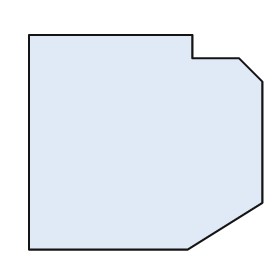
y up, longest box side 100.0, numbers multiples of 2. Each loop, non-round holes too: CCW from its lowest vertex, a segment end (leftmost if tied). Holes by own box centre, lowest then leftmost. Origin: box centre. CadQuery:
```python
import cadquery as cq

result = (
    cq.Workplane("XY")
    .moveTo(-50.0, -46.0)
    .lineTo(18.0, -46.0)
    .lineTo(50.0, -26.0)
    .lineTo(50.0, 26.0)
    .lineTo(40.0, 36.0)
    .lineTo(20.0, 36.0)
    .lineTo(20.0, 46.0)
    .lineTo(-50.0, 46.0)
    .close()
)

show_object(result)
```